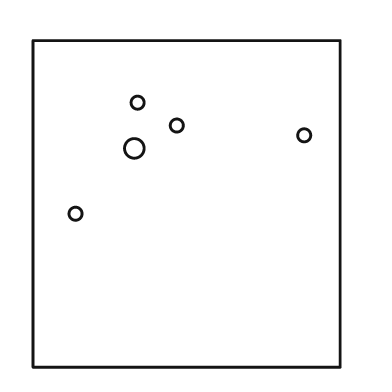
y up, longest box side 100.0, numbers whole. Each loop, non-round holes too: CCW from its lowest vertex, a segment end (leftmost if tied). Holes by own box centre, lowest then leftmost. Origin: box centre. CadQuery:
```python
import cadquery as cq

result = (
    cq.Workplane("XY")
    .moveTo(-47.0, -50.0)
    .lineTo(47.0, -50.0)
    .lineTo(47.0, 50.0)
    .lineTo(-47.0, 50.0)
    .close()
    .moveTo(-34.0, -3.0)
    .circle(2.0)
    .moveTo(-16.0, 17.0)
    .circle(3.0)
    .moveTo(36.0, 21.0)
    .circle(2.0)
    .moveTo(-3.0, 24.0)
    .circle(2.0)
    .moveTo(-15.0, 31.0)
    .circle(2.0)
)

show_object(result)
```